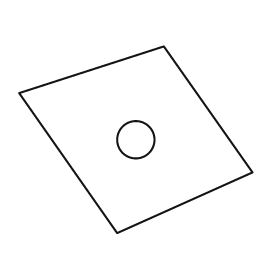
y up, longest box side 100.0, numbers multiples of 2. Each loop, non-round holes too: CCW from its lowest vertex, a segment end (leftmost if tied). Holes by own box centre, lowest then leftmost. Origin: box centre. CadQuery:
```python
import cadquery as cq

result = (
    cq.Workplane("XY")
    .moveTo(-8.0, -40.0)
    .lineTo(50.0, -14.0)
    .lineTo(12.0, 40.0)
    .lineTo(-50.0, 20.0)
    .close()
    .moveTo(0.0, 0.0)
    .circle(8.0)
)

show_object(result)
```